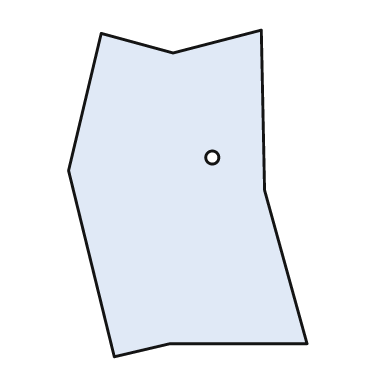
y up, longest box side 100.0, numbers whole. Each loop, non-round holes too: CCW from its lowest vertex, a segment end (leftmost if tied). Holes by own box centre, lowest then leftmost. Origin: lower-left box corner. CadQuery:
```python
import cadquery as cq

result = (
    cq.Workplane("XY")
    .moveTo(14.0, 0.0)
    .lineTo(31.0, 4.0)
    .lineTo(73.0, 4.0)
    .lineTo(60.0, 51.0)
    .lineTo(59.0, 100.0)
    .lineTo(32.0, 93.0)
    .lineTo(10.0, 99.0)
    .lineTo(0.0, 57.0)
    .close()
    .moveTo(44.0, 61.0)
    .circle(2.0)
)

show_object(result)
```